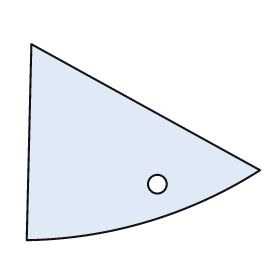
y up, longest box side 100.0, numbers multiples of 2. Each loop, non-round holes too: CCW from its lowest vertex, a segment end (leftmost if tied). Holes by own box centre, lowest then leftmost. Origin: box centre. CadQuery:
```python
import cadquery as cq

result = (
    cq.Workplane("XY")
    .moveTo(-50.0, -42.0)
    .threePointArc((2.0, -34.0), (50.0, -12.0))
    .lineTo(-48.0, 42.0)
    .close()
    .moveTo(6.0, -18.0)
    .circle(4.0)
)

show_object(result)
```